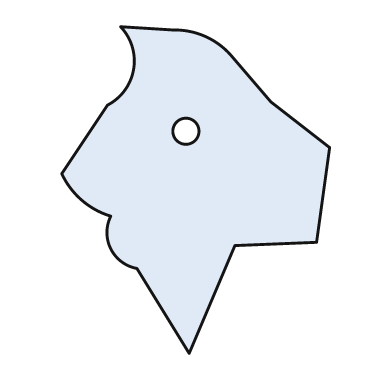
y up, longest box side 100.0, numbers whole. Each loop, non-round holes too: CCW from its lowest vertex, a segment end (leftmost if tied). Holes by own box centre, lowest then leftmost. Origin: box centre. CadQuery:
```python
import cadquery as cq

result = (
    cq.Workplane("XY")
    .moveTo(-2.0, -50.0)
    .lineTo(12.0, -17.0)
    .lineTo(37.0, -16.0)
    .lineTo(41.0, 13.0)
    .lineTo(23.0, 27.0)
    .lineTo(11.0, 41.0)
    .threePointArc((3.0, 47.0), (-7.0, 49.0))
    .lineTo(-23.0, 50.0)
    .threePointArc((-19.0, 37.0), (-27.0, 26.0))
    .lineTo(-41.0, 5.0)
    .threePointArc((-35.0, -3.0), (-26.0, -8.0))
    .threePointArc((-26.0, -18.0), (-18.0, -24.0))
    .close()
    .moveTo(-3.0, 18.0)
    .circle(4.0)
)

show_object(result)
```